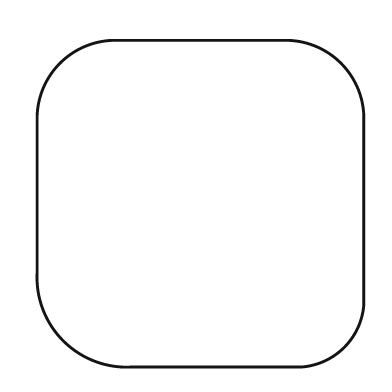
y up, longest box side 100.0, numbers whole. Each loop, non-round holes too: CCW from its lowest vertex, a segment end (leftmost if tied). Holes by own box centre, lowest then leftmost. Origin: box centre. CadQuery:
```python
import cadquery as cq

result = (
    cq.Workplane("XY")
    .moveTo(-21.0, -50.0)
    .lineTo(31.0, -50.0)
    .threePointArc((44.0, -44.0), (50.0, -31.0))
    .lineTo(50.0, 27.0)
    .threePointArc((43.0, 43.0), (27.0, 50.0))
    .lineTo(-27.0, 50.0)
    .threePointArc((-43.0, 43.0), (-50.0, 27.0))
    .lineTo(-50.0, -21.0)
    .threePointArc((-42.0, -42.0), (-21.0, -50.0))
    .close()
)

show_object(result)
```